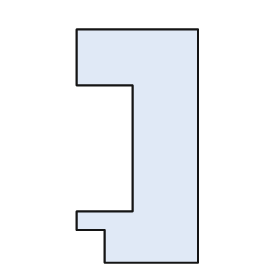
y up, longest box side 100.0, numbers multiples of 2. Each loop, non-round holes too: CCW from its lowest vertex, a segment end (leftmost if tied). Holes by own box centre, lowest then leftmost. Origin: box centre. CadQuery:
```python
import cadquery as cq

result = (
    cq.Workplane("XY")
    .moveTo(-14.0, -50.0)
    .lineTo(26.0, -50.0)
    .lineTo(26.0, 50.0)
    .lineTo(-26.0, 50.0)
    .lineTo(-26.0, 26.0)
    .lineTo(-2.0, 26.0)
    .lineTo(-2.0, -28.0)
    .lineTo(-26.0, -28.0)
    .lineTo(-26.0, -36.0)
    .lineTo(-14.0, -36.0)
    .close()
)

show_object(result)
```